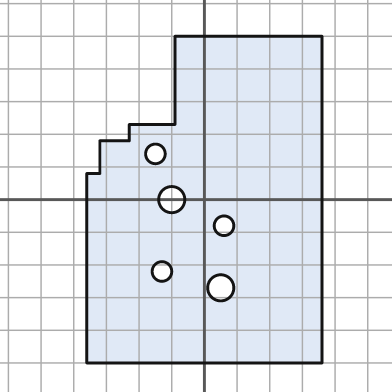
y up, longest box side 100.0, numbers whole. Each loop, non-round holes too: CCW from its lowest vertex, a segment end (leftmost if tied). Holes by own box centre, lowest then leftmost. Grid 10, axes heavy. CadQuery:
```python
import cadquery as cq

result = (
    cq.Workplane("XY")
    .moveTo(-36.0, -50.0)
    .lineTo(36.0, -50.0)
    .lineTo(36.0, 50.0)
    .lineTo(-9.0, 50.0)
    .lineTo(-9.0, 23.0)
    .lineTo(-23.0, 23.0)
    .lineTo(-23.0, 18.0)
    .lineTo(-32.0, 18.0)
    .lineTo(-32.0, 8.0)
    .lineTo(-36.0, 8.0)
    .close()
    .moveTo(5.0, -27.0)
    .circle(4.0)
    .moveTo(-13.0, -22.0)
    .circle(3.0)
    .moveTo(6.0, -8.0)
    .circle(3.0)
    .moveTo(-10.0, 0.0)
    .circle(4.0)
    .moveTo(-15.0, 14.0)
    .circle(3.0)
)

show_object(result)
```